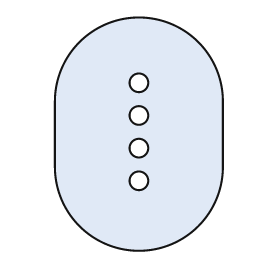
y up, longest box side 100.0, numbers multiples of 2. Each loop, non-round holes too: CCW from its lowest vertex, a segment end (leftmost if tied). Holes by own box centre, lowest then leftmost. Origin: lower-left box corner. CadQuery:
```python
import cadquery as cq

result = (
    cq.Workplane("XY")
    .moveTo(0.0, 36.0)
    .threePointArc((36.0, 0.0), (72.0, 36.0))
    .lineTo(72.0, 64.0)
    .threePointArc((36.0, 100.0), (0.0, 64.0))
    .close()
    .moveTo(36.0, 30.0)
    .circle(4.0)
    .moveTo(36.0, 44.0)
    .circle(4.0)
    .moveTo(36.0, 58.0)
    .circle(4.0)
    .moveTo(36.0, 72.0)
    .circle(4.0)
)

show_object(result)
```